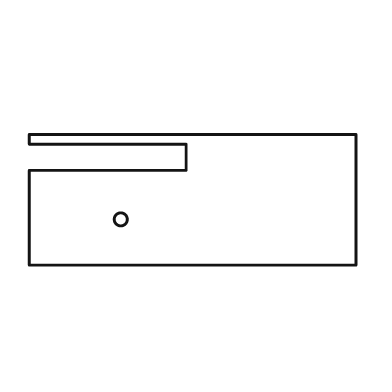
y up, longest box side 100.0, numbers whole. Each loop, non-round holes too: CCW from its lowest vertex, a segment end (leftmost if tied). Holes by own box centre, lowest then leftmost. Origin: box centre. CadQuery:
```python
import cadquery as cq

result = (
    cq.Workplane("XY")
    .moveTo(-50.0, -20.0)
    .lineTo(50.0, -20.0)
    .lineTo(50.0, 20.0)
    .lineTo(-50.0, 20.0)
    .lineTo(-50.0, 17.0)
    .lineTo(-2.0, 17.0)
    .lineTo(-2.0, 9.0)
    .lineTo(-50.0, 9.0)
    .close()
    .moveTo(-22.0, -6.0)
    .circle(2.0)
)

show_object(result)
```